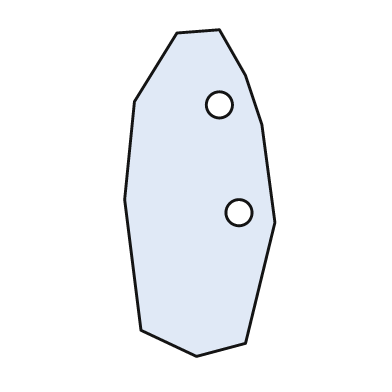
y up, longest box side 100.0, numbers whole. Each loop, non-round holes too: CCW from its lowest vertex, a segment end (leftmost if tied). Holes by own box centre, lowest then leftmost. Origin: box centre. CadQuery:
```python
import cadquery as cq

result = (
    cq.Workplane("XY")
    .moveTo(-1.0, -50.0)
    .lineTo(14.0, -46.0)
    .lineTo(23.0, -9.0)
    .lineTo(19.0, 21.0)
    .lineTo(14.0, 36.0)
    .lineTo(6.0, 50.0)
    .lineTo(-7.0, 49.0)
    .lineTo(-20.0, 28.0)
    .lineTo(-23.0, -2.0)
    .lineTo(-18.0, -42.0)
    .close()
    .moveTo(12.0, -6.0)
    .circle(4.0)
    .moveTo(6.0, 27.0)
    .circle(4.0)
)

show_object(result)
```